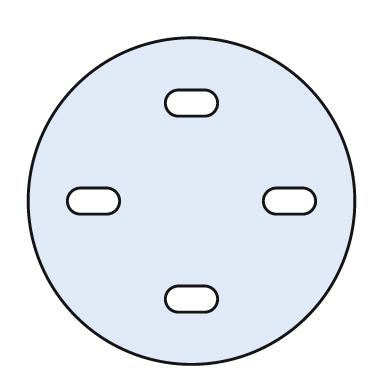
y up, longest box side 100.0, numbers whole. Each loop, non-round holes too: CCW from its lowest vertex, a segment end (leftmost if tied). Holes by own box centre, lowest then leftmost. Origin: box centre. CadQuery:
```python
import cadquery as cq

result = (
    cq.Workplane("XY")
    .moveTo(0.0, 0.0)
    .circle(50.0)
    .moveTo(-4.0, -34.0)
    .lineTo(4.0, -34.0)
    .threePointArc((8.0, -30.0), (4.0, -26.0))
    .lineTo(-4.0, -26.0)
    .threePointArc((-8.0, -30.0), (-4.0, -34.0))
    .close()
    .moveTo(-34.0, -4.0)
    .lineTo(-26.0, -4.0)
    .threePointArc((-22.0, 0.0), (-26.0, 4.0))
    .lineTo(-34.0, 4.0)
    .threePointArc((-38.0, 0.0), (-34.0, -4.0))
    .close()
    .moveTo(26.0, -4.0)
    .lineTo(34.0, -4.0)
    .threePointArc((38.0, 0.0), (34.0, 4.0))
    .lineTo(26.0, 4.0)
    .threePointArc((22.0, 0.0), (26.0, -4.0))
    .close()
    .moveTo(-4.0, 26.0)
    .lineTo(4.0, 26.0)
    .threePointArc((8.0, 30.0), (4.0, 34.0))
    .lineTo(-4.0, 34.0)
    .threePointArc((-8.0, 30.0), (-4.0, 26.0))
    .close()
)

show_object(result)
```